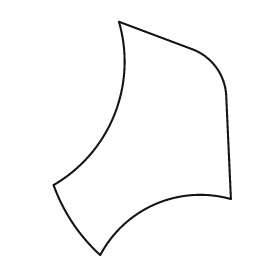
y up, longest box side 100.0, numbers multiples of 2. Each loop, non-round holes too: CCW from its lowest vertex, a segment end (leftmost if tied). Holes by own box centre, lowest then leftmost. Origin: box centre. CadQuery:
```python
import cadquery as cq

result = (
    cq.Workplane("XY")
    .moveTo(-18.0, -50.0)
    .threePointArc((6.0, -28.0), (38.0, -26.0))
    .lineTo(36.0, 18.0)
    .threePointArc((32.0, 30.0), (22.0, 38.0))
    .lineTo(-10.0, 50.0)
    .threePointArc((-12.0, 10.0), (-38.0, -20.0))
    .threePointArc((-30.0, -36.0), (-18.0, -50.0))
    .close()
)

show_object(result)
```